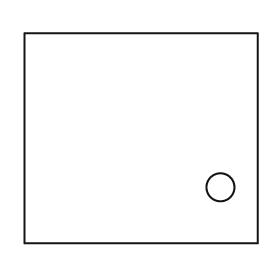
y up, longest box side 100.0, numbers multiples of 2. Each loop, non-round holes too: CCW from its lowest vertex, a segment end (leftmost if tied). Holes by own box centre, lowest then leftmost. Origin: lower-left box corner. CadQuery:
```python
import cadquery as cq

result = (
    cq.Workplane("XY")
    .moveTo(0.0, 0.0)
    .lineTo(100.0, 0.0)
    .lineTo(100.0, 90.0)
    .lineTo(0.0, 90.0)
    .close()
    .moveTo(84.0, 24.0)
    .circle(6.0)
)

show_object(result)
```